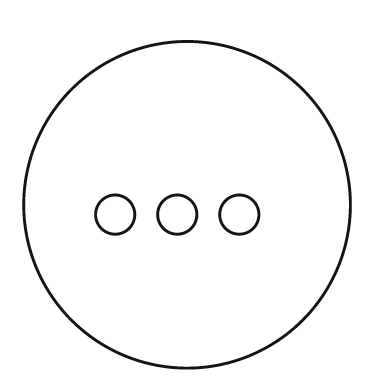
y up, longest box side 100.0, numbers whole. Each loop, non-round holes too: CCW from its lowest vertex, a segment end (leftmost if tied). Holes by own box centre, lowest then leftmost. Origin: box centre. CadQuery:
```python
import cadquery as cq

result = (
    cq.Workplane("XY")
    .moveTo(0.0, 0.0)
    .circle(50.0)
    .moveTo(-22.0, -3.0)
    .circle(6.0)
    .moveTo(-3.0, -3.0)
    .circle(6.0)
    .moveTo(16.0, -3.0)
    .circle(6.0)
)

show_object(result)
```